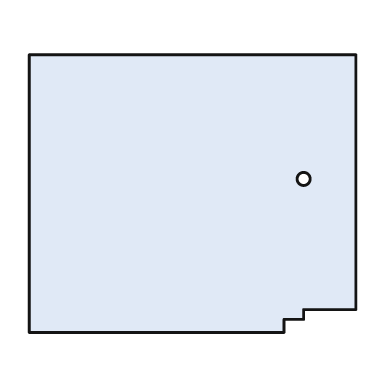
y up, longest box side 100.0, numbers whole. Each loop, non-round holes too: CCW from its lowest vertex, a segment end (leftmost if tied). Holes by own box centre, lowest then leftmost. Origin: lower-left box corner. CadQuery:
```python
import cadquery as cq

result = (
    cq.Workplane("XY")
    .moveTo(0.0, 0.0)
    .lineTo(78.0, 0.0)
    .lineTo(78.0, 4.0)
    .lineTo(84.0, 4.0)
    .lineTo(84.0, 7.0)
    .lineTo(100.0, 7.0)
    .lineTo(100.0, 85.0)
    .lineTo(0.0, 85.0)
    .close()
    .moveTo(84.0, 47.0)
    .circle(2.0)
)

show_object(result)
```